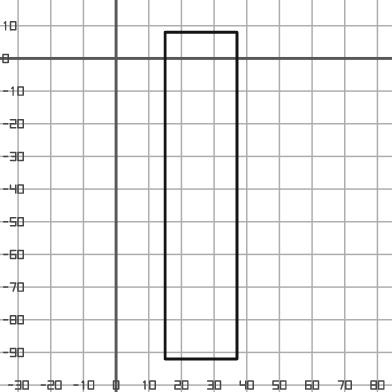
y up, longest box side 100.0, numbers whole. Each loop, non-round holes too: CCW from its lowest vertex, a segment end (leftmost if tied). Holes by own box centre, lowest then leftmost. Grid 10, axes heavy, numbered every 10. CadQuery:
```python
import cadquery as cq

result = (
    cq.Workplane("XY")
    .moveTo(15.0, -92.0)
    .lineTo(37.0, -92.0)
    .lineTo(37.0, 8.0)
    .lineTo(15.0, 8.0)
    .close()
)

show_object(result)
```